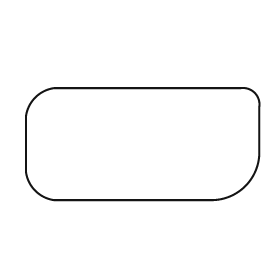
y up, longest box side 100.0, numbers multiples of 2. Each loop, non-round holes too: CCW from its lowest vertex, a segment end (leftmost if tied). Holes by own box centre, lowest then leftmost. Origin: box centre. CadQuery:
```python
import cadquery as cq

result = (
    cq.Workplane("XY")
    .moveTo(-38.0, -24.0)
    .lineTo(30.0, -24.0)
    .threePointArc((44.0, -18.0), (50.0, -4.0))
    .lineTo(50.0, 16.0)
    .threePointArc((48.0, 22.0), (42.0, 24.0))
    .lineTo(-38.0, 24.0)
    .threePointArc((-46.0, 20.0), (-50.0, 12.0))
    .lineTo(-50.0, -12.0)
    .threePointArc((-46.0, -20.0), (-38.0, -24.0))
    .close()
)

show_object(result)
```